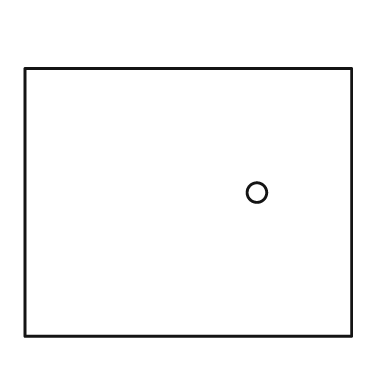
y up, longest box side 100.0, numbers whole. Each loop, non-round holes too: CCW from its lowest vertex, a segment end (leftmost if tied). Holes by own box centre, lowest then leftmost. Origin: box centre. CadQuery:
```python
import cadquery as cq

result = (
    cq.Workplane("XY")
    .moveTo(-50.0, -41.0)
    .lineTo(50.0, -41.0)
    .lineTo(50.0, 41.0)
    .lineTo(-50.0, 41.0)
    .close()
    .moveTo(21.0, 3.0)
    .circle(3.0)
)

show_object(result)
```